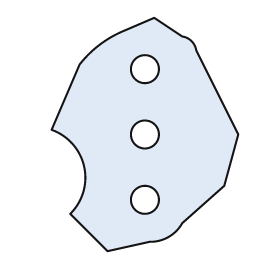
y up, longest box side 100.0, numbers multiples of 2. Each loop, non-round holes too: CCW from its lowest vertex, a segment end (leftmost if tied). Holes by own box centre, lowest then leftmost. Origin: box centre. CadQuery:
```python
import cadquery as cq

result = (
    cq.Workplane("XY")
    .moveTo(-16.0, -50.0)
    .lineTo(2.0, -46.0)
    .threePointArc((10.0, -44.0), (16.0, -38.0))
    .lineTo(34.0, -22.0)
    .lineTo(40.0, 0.0)
    .lineTo(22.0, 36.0)
    .threePointArc((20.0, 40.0), (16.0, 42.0))
    .lineTo(4.0, 50.0)
    .lineTo(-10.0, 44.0)
    .threePointArc((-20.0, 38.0), (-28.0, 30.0))
    .lineTo(-40.0, 2.0)
    .threePointArc((-26.0, -14.0), (-32.0, -34.0))
    .close()
    .moveTo(0.0, -28.0)
    .circle(6.0)
    .moveTo(0.0, 0.0)
    .circle(6.0)
    .moveTo(0.0, 28.0)
    .circle(6.0)
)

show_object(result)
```